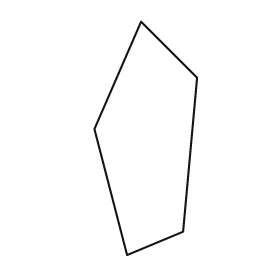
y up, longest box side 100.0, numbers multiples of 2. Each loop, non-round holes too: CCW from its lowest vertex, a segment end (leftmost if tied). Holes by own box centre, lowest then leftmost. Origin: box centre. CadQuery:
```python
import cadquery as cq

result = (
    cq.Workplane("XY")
    .moveTo(-8.0, -50.0)
    .lineTo(16.0, -40.0)
    .lineTo(22.0, 26.0)
    .lineTo(-2.0, 50.0)
    .lineTo(-22.0, 4.0)
    .close()
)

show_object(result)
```